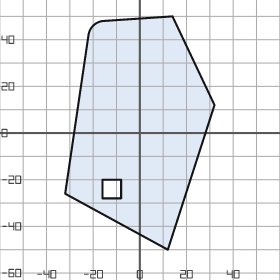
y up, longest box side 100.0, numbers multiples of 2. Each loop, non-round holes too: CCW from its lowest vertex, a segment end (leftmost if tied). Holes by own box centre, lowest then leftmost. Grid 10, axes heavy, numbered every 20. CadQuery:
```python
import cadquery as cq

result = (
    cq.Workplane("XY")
    .moveTo(12.0, -50.0)
    .lineTo(32.0, 12.0)
    .lineTo(14.0, 50.0)
    .lineTo(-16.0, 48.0)
    .threePointArc((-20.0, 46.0), (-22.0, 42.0))
    .lineTo(-32.0, -26.0)
    .close()
    .moveTo(-16.0, -28.0)
    .lineTo(-8.0, -28.0)
    .lineTo(-8.0, -20.0)
    .lineTo(-16.0, -20.0)
    .close()
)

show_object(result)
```